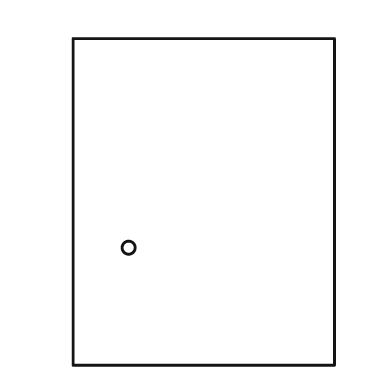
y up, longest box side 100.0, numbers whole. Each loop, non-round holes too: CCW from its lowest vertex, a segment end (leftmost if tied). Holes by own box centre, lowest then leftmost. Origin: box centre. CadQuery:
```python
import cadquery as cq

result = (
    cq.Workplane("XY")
    .moveTo(-40.0, -50.0)
    .lineTo(40.0, -50.0)
    .lineTo(40.0, 50.0)
    .lineTo(-40.0, 50.0)
    .close()
    .moveTo(-23.0, -14.0)
    .circle(2.0)
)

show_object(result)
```